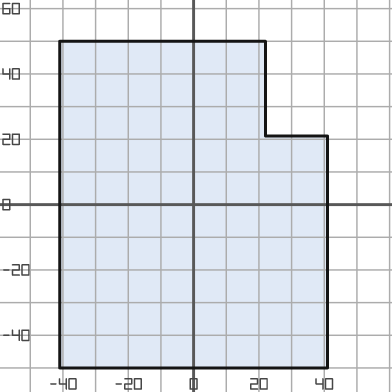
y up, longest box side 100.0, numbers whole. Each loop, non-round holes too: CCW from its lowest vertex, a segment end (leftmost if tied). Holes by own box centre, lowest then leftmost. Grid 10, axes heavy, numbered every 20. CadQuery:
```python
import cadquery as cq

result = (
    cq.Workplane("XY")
    .moveTo(-41.0, -50.0)
    .lineTo(41.0, -50.0)
    .lineTo(41.0, 21.0)
    .lineTo(22.0, 21.0)
    .lineTo(22.0, 50.0)
    .lineTo(-41.0, 50.0)
    .close()
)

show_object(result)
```